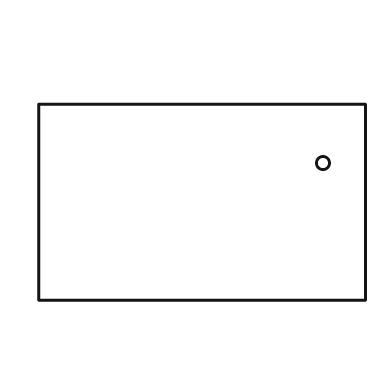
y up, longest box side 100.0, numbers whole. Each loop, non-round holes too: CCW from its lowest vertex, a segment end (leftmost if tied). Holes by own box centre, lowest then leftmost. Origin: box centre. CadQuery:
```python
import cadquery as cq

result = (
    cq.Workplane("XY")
    .moveTo(-50.0, -30.0)
    .lineTo(50.0, -30.0)
    .lineTo(50.0, 30.0)
    .lineTo(-50.0, 30.0)
    .close()
    .moveTo(37.0, 12.0)
    .circle(2.0)
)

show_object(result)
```